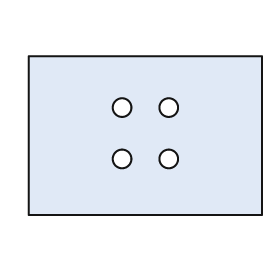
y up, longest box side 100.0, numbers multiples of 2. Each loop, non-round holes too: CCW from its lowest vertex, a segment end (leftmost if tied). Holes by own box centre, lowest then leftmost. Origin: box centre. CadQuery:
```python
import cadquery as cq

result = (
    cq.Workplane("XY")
    .moveTo(-50.0, -34.0)
    .lineTo(50.0, -34.0)
    .lineTo(50.0, 34.0)
    .lineTo(-50.0, 34.0)
    .close()
    .moveTo(-10.0, -10.0)
    .circle(4.0)
    .moveTo(10.0, -10.0)
    .circle(4.0)
    .moveTo(-10.0, 12.0)
    .circle(4.0)
    .moveTo(10.0, 12.0)
    .circle(4.0)
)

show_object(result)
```